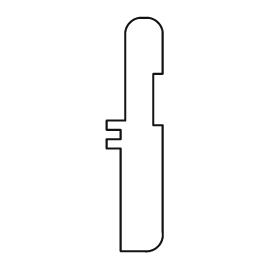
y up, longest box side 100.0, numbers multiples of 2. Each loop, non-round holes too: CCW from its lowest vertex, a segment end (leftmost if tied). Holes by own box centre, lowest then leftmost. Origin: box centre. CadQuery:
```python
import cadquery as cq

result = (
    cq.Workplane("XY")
    .moveTo(-6.0, -50.0)
    .lineTo(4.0, -50.0)
    .threePointArc((10.0, -48.0), (12.0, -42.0))
    .lineTo(12.0, 4.0)
    .lineTo(8.0, 4.0)
    .lineTo(8.0, 26.0)
    .lineTo(12.0, 26.0)
    .lineTo(12.0, 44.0)
    .threePointArc((10.0, 48.0), (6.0, 50.0))
    .lineTo(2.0, 50.0)
    .threePointArc((-2.0, 48.0), (-4.0, 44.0))
    .lineTo(-4.0, 6.0)
    .lineTo(-12.0, 6.0)
    .lineTo(-12.0, 2.0)
    .lineTo(-6.0, 2.0)
    .lineTo(-6.0, -2.0)
    .lineTo(-12.0, -2.0)
    .lineTo(-12.0, -6.0)
    .lineTo(-6.0, -6.0)
    .close()
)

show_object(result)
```